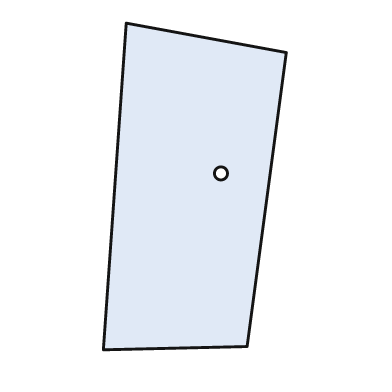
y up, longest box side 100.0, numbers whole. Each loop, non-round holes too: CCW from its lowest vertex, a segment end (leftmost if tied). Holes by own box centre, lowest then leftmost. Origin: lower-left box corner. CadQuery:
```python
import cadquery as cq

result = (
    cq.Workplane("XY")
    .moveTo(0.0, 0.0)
    .lineTo(44.0, 1.0)
    .lineTo(56.0, 91.0)
    .lineTo(7.0, 100.0)
    .close()
    .moveTo(36.0, 54.0)
    .circle(2.0)
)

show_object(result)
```